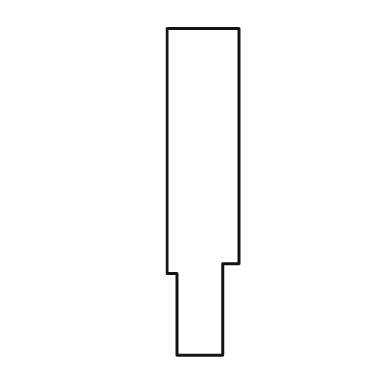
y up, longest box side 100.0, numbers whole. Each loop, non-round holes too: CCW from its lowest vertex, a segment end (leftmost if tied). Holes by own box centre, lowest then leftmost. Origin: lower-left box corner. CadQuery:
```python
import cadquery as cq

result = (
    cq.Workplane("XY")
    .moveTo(3.0, 0.0)
    .lineTo(17.0, 0.0)
    .lineTo(17.0, 28.0)
    .lineTo(22.0, 28.0)
    .lineTo(22.0, 100.0)
    .lineTo(0.0, 100.0)
    .lineTo(0.0, 25.0)
    .lineTo(3.0, 25.0)
    .close()
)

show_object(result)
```